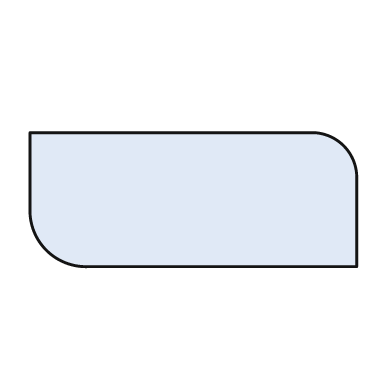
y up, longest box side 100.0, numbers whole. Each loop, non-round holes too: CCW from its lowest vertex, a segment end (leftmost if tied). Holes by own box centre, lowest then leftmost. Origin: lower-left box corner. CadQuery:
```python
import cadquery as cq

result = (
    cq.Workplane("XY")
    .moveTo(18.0, 0.0)
    .lineTo(100.0, 0.0)
    .lineTo(100.0, 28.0)
    .threePointArc((96.0, 37.0), (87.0, 41.0))
    .lineTo(0.0, 41.0)
    .lineTo(0.0, 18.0)
    .threePointArc((5.0, 5.0), (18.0, 0.0))
    .close()
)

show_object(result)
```